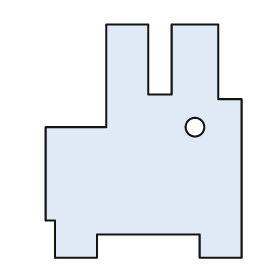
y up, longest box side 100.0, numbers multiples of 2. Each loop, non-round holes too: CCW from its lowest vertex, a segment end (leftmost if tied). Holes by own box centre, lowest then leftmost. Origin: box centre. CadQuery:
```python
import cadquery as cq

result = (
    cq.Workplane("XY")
    .moveTo(-38.0, -50.0)
    .lineTo(-20.0, -50.0)
    .lineTo(-20.0, -40.0)
    .lineTo(24.0, -40.0)
    .lineTo(24.0, -50.0)
    .lineTo(42.0, -50.0)
    .lineTo(42.0, 18.0)
    .lineTo(32.0, 18.0)
    .lineTo(32.0, 50.0)
    .lineTo(12.0, 50.0)
    .lineTo(12.0, 20.0)
    .lineTo(2.0, 20.0)
    .lineTo(2.0, 50.0)
    .lineTo(-16.0, 50.0)
    .lineTo(-16.0, 6.0)
    .lineTo(-42.0, 6.0)
    .lineTo(-42.0, -34.0)
    .lineTo(-38.0, -34.0)
    .close()
    .moveTo(22.0, 6.0)
    .circle(4.0)
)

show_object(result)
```